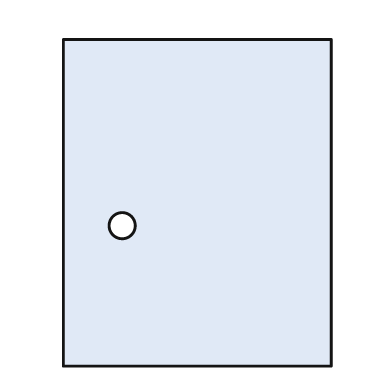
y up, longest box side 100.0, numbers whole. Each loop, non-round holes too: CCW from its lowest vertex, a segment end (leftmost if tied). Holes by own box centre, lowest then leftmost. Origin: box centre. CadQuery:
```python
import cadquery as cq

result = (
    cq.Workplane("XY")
    .moveTo(-41.0, -50.0)
    .lineTo(41.0, -50.0)
    .lineTo(41.0, 50.0)
    .lineTo(-41.0, 50.0)
    .close()
    .moveTo(-23.0, -7.0)
    .circle(4.0)
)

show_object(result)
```